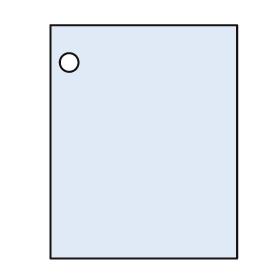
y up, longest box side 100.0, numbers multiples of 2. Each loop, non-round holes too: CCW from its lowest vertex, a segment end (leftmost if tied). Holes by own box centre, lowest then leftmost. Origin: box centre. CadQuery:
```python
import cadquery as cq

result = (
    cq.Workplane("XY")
    .moveTo(-40.0, -50.0)
    .lineTo(40.0, -50.0)
    .lineTo(40.0, 50.0)
    .lineTo(-40.0, 50.0)
    .close()
    .moveTo(-32.0, 34.0)
    .circle(4.0)
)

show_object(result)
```